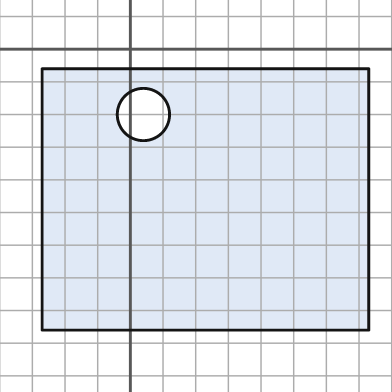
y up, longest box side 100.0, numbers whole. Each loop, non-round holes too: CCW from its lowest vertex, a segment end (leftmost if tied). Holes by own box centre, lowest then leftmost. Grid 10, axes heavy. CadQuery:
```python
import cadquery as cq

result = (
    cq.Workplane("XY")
    .moveTo(-27.0, -86.0)
    .lineTo(73.0, -86.0)
    .lineTo(73.0, -6.0)
    .lineTo(-27.0, -6.0)
    .close()
    .moveTo(4.0, -20.0)
    .circle(8.0)
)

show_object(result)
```